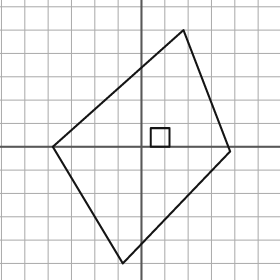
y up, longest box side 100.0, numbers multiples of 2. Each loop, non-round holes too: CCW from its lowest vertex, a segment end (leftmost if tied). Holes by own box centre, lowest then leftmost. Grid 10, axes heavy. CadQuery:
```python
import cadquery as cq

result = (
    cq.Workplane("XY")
    .moveTo(-8.0, -50.0)
    .lineTo(38.0, -2.0)
    .lineTo(18.0, 50.0)
    .lineTo(-38.0, 0.0)
    .close()
    .moveTo(4.0, 0.0)
    .lineTo(12.0, 0.0)
    .lineTo(12.0, 8.0)
    .lineTo(4.0, 8.0)
    .close()
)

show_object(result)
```